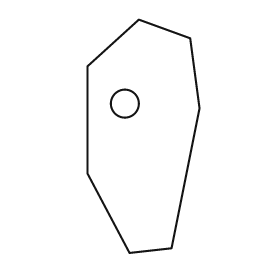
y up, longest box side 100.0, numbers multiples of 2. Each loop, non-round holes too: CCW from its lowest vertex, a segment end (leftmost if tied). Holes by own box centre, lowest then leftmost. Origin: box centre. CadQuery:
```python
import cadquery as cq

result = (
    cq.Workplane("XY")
    .moveTo(-6.0, -50.0)
    .lineTo(12.0, -48.0)
    .lineTo(24.0, 12.0)
    .lineTo(20.0, 42.0)
    .lineTo(-2.0, 50.0)
    .lineTo(-24.0, 30.0)
    .lineTo(-24.0, -16.0)
    .close()
    .moveTo(-8.0, 14.0)
    .circle(6.0)
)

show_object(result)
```